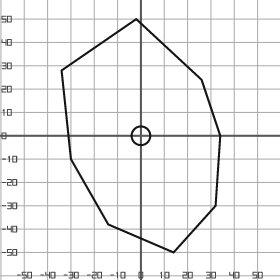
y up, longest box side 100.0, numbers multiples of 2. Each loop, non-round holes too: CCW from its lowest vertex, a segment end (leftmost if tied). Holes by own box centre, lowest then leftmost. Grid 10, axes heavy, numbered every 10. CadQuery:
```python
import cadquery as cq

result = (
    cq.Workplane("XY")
    .moveTo(14.0, -50.0)
    .lineTo(32.0, -30.0)
    .lineTo(34.0, 0.0)
    .lineTo(26.0, 24.0)
    .lineTo(-2.0, 50.0)
    .lineTo(-34.0, 28.0)
    .lineTo(-30.0, -10.0)
    .lineTo(-14.0, -38.0)
    .close()
    .moveTo(0.0, 0.0)
    .circle(4.0)
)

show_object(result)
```